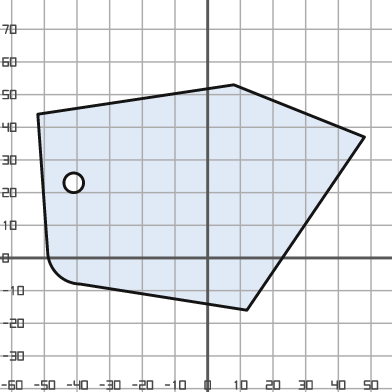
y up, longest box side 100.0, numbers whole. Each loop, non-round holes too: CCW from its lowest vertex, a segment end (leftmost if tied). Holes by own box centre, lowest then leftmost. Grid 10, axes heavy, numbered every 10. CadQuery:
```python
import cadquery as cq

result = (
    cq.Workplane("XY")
    .moveTo(12.0, -16.0)
    .lineTo(48.0, 37.0)
    .lineTo(8.0, 53.0)
    .lineTo(-52.0, 44.0)
    .lineTo(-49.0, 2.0)
    .threePointArc((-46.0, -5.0), (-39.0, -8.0))
    .close()
    .moveTo(-41.0, 23.0)
    .circle(3.0)
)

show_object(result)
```